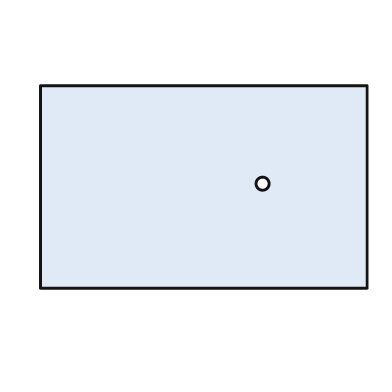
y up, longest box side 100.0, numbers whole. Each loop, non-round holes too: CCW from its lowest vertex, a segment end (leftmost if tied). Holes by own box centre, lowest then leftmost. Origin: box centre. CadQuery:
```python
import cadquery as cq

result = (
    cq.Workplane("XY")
    .moveTo(-50.0, -31.0)
    .lineTo(50.0, -31.0)
    .lineTo(50.0, 31.0)
    .lineTo(-50.0, 31.0)
    .close()
    .moveTo(18.0, 1.0)
    .circle(2.0)
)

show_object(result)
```